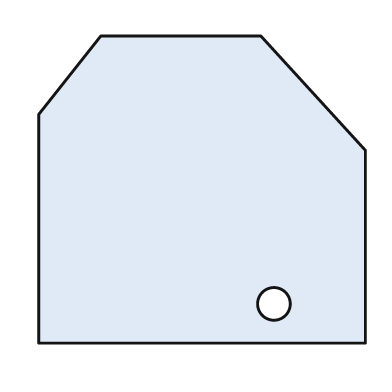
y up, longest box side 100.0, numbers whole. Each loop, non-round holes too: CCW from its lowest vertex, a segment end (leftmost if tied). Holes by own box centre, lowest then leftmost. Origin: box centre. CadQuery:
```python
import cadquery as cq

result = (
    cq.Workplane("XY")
    .moveTo(-50.0, -47.0)
    .lineTo(50.0, -47.0)
    .lineTo(50.0, 12.0)
    .lineTo(18.0, 47.0)
    .lineTo(-31.0, 47.0)
    .lineTo(-50.0, 23.0)
    .close()
    .moveTo(22.0, -35.0)
    .circle(5.0)
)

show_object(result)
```